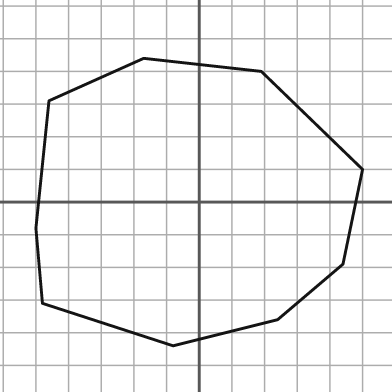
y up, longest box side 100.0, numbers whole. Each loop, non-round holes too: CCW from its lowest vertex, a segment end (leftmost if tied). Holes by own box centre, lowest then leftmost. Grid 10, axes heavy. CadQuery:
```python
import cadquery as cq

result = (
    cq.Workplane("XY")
    .moveTo(-8.0, -44.0)
    .lineTo(24.0, -36.0)
    .lineTo(44.0, -19.0)
    .lineTo(50.0, 10.0)
    .lineTo(19.0, 40.0)
    .lineTo(-17.0, 44.0)
    .lineTo(-46.0, 31.0)
    .lineTo(-50.0, -8.0)
    .lineTo(-48.0, -31.0)
    .close()
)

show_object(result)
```